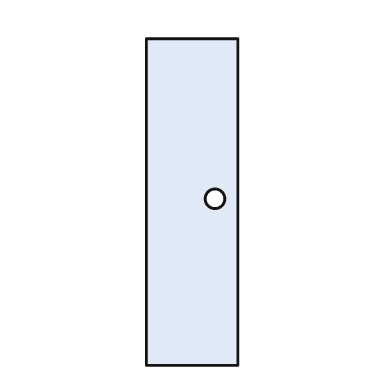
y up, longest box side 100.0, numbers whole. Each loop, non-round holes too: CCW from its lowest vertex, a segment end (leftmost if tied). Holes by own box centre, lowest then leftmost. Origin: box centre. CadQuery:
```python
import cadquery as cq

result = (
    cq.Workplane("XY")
    .moveTo(-14.0, -50.0)
    .lineTo(14.0, -50.0)
    .lineTo(14.0, 50.0)
    .lineTo(-14.0, 50.0)
    .close()
    .moveTo(7.0, 1.0)
    .circle(3.0)
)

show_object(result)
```